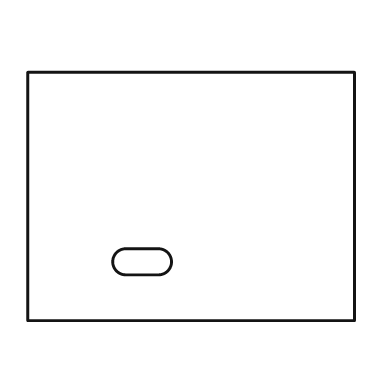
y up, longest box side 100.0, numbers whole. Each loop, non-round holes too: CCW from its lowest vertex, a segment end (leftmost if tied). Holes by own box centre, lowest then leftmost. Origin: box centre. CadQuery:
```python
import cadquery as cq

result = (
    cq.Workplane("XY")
    .moveTo(-50.0, -38.0)
    .lineTo(50.0, -38.0)
    .lineTo(50.0, 38.0)
    .lineTo(-50.0, 38.0)
    .close()
    .moveTo(-20.0, -24.0)
    .lineTo(-10.0, -24.0)
    .threePointArc((-6.0, -20.0), (-10.0, -16.0))
    .lineTo(-20.0, -16.0)
    .threePointArc((-24.0, -20.0), (-20.0, -24.0))
    .close()
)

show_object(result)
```